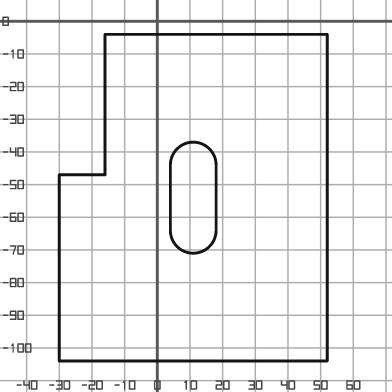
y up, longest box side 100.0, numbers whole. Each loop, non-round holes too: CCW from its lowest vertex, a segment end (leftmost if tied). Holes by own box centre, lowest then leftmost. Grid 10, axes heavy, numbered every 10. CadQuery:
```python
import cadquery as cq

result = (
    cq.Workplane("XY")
    .moveTo(-30.0, -104.0)
    .lineTo(52.0, -104.0)
    .lineTo(52.0, -4.0)
    .lineTo(-16.0, -4.0)
    .lineTo(-16.0, -47.0)
    .lineTo(-30.0, -47.0)
    .close()
    .moveTo(4.0, -64.0)
    .threePointArc((11.0, -71.0), (18.0, -64.0))
    .lineTo(18.0, -44.0)
    .threePointArc((11.0, -37.0), (4.0, -44.0))
    .close()
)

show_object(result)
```